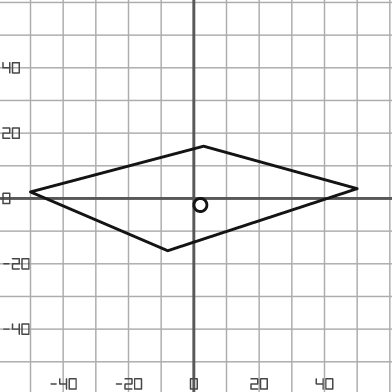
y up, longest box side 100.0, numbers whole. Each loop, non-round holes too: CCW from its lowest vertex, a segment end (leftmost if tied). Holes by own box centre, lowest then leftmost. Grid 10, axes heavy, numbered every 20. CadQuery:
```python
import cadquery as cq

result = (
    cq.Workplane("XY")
    .moveTo(-8.0, -16.0)
    .lineTo(50.0, 3.0)
    .lineTo(3.0, 16.0)
    .lineTo(-50.0, 2.0)
    .close()
    .moveTo(2.0, -2.0)
    .circle(2.0)
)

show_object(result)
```